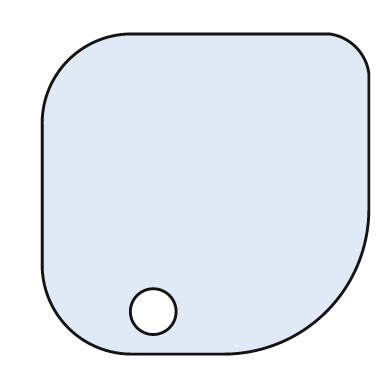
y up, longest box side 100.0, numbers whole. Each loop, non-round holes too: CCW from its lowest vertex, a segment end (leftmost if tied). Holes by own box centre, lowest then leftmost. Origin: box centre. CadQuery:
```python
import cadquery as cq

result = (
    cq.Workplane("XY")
    .moveTo(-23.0, -49.0)
    .lineTo(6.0, -49.0)
    .threePointArc((37.0, -36.0), (50.0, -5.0))
    .lineTo(50.0, 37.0)
    .threePointArc((46.0, 45.0), (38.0, 49.0))
    .lineTo(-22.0, 49.0)
    .threePointArc((-42.0, 41.0), (-50.0, 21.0))
    .lineTo(-50.0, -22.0)
    .threePointArc((-42.0, -41.0), (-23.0, -49.0))
    .close()
    .moveTo(-16.0, -36.0)
    .circle(7.0)
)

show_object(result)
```